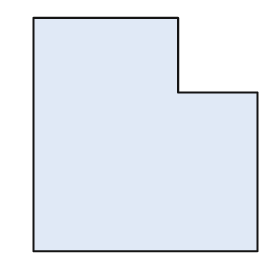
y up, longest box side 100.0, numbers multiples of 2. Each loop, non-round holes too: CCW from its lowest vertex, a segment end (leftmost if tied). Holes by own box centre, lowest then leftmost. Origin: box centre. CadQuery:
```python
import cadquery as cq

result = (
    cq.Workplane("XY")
    .moveTo(-48.0, -50.0)
    .lineTo(48.0, -50.0)
    .lineTo(48.0, 18.0)
    .lineTo(14.0, 18.0)
    .lineTo(14.0, 50.0)
    .lineTo(-48.0, 50.0)
    .close()
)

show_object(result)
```